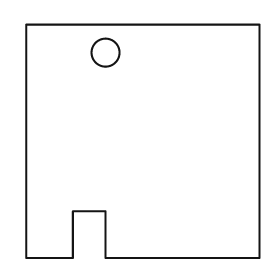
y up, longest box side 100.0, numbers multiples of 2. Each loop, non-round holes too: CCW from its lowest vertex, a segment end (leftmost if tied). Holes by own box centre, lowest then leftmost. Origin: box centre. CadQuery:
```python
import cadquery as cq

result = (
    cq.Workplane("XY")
    .moveTo(-50.0, -50.0)
    .lineTo(-30.0, -50.0)
    .lineTo(-30.0, -30.0)
    .lineTo(-16.0, -30.0)
    .lineTo(-16.0, -50.0)
    .lineTo(50.0, -50.0)
    .lineTo(50.0, 50.0)
    .lineTo(-50.0, 50.0)
    .close()
    .moveTo(-16.0, 38.0)
    .circle(6.0)
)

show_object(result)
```